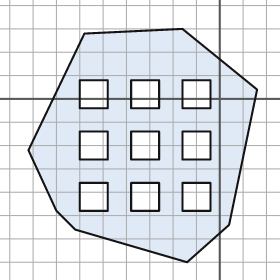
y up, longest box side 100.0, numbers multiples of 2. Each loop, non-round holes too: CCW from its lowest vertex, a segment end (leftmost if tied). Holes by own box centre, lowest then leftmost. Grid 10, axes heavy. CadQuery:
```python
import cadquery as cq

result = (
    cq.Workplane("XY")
    .moveTo(-14.0, -70.0)
    .lineTo(4.0, -54.0)
    .lineTo(16.0, 4.0)
    .lineTo(-16.0, 30.0)
    .lineTo(-58.0, 28.0)
    .lineTo(-82.0, -22.0)
    .lineTo(-70.0, -48.0)
    .lineTo(-62.0, -56.0)
    .close()
    .moveTo(-60.0, -48.0)
    .lineTo(-48.0, -48.0)
    .lineTo(-48.0, -36.0)
    .lineTo(-60.0, -36.0)
    .close()
    .moveTo(-38.0, -48.0)
    .lineTo(-26.0, -48.0)
    .lineTo(-26.0, -36.0)
    .lineTo(-38.0, -36.0)
    .close()
    .moveTo(-16.0, -48.0)
    .lineTo(-4.0, -48.0)
    .lineTo(-4.0, -36.0)
    .lineTo(-16.0, -36.0)
    .close()
    .moveTo(-60.0, -26.0)
    .lineTo(-48.0, -26.0)
    .lineTo(-48.0, -14.0)
    .lineTo(-60.0, -14.0)
    .close()
    .moveTo(-38.0, -26.0)
    .lineTo(-26.0, -26.0)
    .lineTo(-26.0, -14.0)
    .lineTo(-38.0, -14.0)
    .close()
    .moveTo(-16.0, -26.0)
    .lineTo(-4.0, -26.0)
    .lineTo(-4.0, -14.0)
    .lineTo(-16.0, -14.0)
    .close()
    .moveTo(-60.0, -4.0)
    .lineTo(-48.0, -4.0)
    .lineTo(-48.0, 8.0)
    .lineTo(-60.0, 8.0)
    .close()
    .moveTo(-38.0, -4.0)
    .lineTo(-26.0, -4.0)
    .lineTo(-26.0, 8.0)
    .lineTo(-38.0, 8.0)
    .close()
    .moveTo(-16.0, -4.0)
    .lineTo(-4.0, -4.0)
    .lineTo(-4.0, 8.0)
    .lineTo(-16.0, 8.0)
    .close()
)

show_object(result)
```